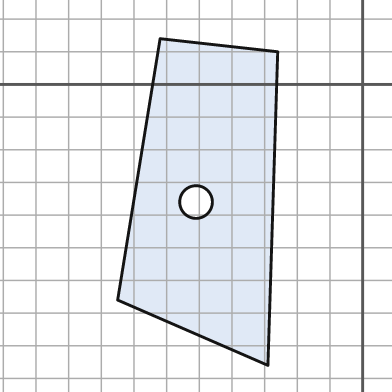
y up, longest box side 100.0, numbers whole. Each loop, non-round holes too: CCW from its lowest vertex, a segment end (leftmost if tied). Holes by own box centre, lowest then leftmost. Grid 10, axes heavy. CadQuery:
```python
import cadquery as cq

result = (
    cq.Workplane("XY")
    .moveTo(-29.0, -86.0)
    .lineTo(-26.0, 10.0)
    .lineTo(-62.0, 14.0)
    .lineTo(-75.0, -66.0)
    .close()
    .moveTo(-51.0, -36.0)
    .circle(5.0)
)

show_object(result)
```